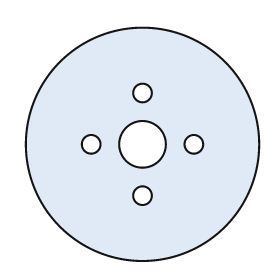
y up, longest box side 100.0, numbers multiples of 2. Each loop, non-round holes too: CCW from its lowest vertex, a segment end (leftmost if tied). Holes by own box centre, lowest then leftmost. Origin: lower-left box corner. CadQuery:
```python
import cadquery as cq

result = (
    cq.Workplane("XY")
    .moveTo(50.0, 50.0)
    .circle(50.0)
    .moveTo(50.0, 28.0)
    .circle(4.0)
    .moveTo(28.0, 50.0)
    .circle(4.0)
    .moveTo(50.0, 50.0)
    .circle(10.0)
    .moveTo(72.0, 50.0)
    .circle(4.0)
    .moveTo(50.0, 72.0)
    .circle(4.0)
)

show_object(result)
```